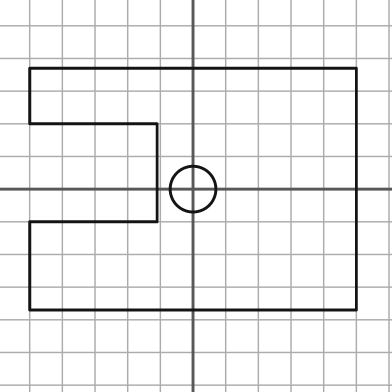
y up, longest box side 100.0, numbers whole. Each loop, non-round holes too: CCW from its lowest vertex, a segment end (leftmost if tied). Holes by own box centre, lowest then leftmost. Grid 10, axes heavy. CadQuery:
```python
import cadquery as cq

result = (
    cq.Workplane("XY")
    .moveTo(-50.0, -37.0)
    .lineTo(50.0, -37.0)
    .lineTo(50.0, 37.0)
    .lineTo(-50.0, 37.0)
    .lineTo(-50.0, 20.0)
    .lineTo(-11.0, 20.0)
    .lineTo(-11.0, -10.0)
    .lineTo(-50.0, -10.0)
    .close()
    .moveTo(0.0, 0.0)
    .circle(7.0)
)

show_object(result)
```